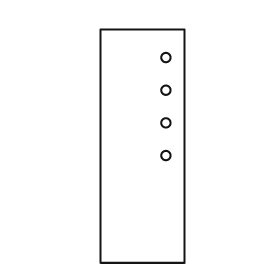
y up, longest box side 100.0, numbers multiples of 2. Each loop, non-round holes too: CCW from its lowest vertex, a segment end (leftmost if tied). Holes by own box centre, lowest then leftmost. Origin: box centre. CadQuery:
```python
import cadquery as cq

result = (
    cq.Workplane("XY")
    .moveTo(-18.0, -50.0)
    .lineTo(18.0, -50.0)
    .lineTo(18.0, 50.0)
    .lineTo(-18.0, 50.0)
    .close()
    .moveTo(10.0, -4.0)
    .circle(2.0)
    .moveTo(10.0, 10.0)
    .circle(2.0)
    .moveTo(10.0, 24.0)
    .circle(2.0)
    .moveTo(10.0, 38.0)
    .circle(2.0)
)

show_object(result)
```